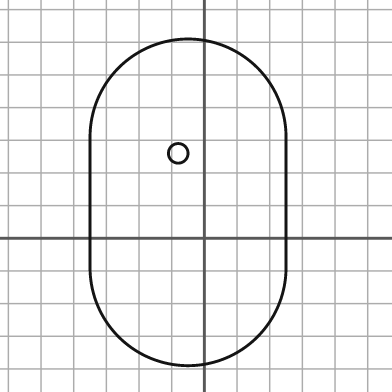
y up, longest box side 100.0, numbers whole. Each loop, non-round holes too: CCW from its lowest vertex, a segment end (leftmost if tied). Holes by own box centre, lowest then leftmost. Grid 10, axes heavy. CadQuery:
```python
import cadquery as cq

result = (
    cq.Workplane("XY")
    .moveTo(-35.0, -9.0)
    .threePointArc((-5.0, -39.0), (25.0, -9.0))
    .lineTo(25.0, 31.0)
    .threePointArc((-5.0, 61.0), (-35.0, 31.0))
    .close()
    .moveTo(-8.0, 26.0)
    .circle(3.0)
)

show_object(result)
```